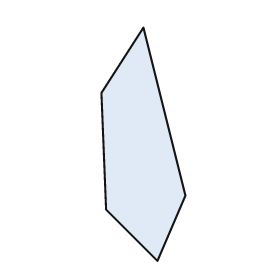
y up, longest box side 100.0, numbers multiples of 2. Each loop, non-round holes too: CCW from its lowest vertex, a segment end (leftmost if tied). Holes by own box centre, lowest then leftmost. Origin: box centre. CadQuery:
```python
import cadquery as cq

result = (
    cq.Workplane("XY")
    .moveTo(6.0, -50.0)
    .lineTo(18.0, -22.0)
    .lineTo(0.0, 50.0)
    .lineTo(-18.0, 22.0)
    .lineTo(-16.0, -28.0)
    .close()
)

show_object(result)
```